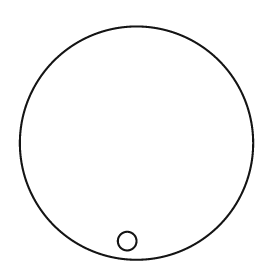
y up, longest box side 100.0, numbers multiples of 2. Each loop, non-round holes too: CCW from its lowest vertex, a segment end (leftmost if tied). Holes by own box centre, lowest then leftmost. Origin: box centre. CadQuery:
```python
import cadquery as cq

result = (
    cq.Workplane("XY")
    .moveTo(0.0, 0.0)
    .circle(50.0)
    .moveTo(-4.0, -42.0)
    .circle(4.0)
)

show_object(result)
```